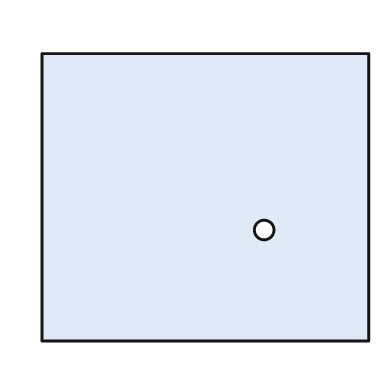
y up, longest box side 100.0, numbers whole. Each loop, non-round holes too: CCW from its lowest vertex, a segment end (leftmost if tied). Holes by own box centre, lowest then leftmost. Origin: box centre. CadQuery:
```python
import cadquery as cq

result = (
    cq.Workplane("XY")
    .moveTo(-50.0, -44.0)
    .lineTo(50.0, -44.0)
    .lineTo(50.0, 44.0)
    .lineTo(-50.0, 44.0)
    .close()
    .moveTo(18.0, -10.0)
    .circle(3.0)
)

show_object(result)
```